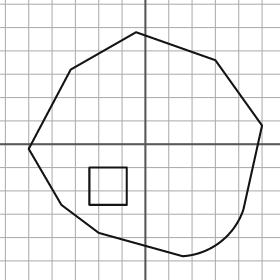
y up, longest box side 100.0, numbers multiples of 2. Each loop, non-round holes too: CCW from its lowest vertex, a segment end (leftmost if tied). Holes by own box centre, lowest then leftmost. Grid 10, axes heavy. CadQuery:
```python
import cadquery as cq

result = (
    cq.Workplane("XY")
    .moveTo(16.0, -48.0)
    .threePointArc((32.0, -42.0), (42.0, -28.0))
    .lineTo(50.0, 8.0)
    .lineTo(30.0, 36.0)
    .lineTo(-4.0, 48.0)
    .lineTo(-32.0, 32.0)
    .lineTo(-50.0, -2.0)
    .lineTo(-36.0, -26.0)
    .lineTo(-20.0, -38.0)
    .close()
    .moveTo(-24.0, -26.0)
    .lineTo(-8.0, -26.0)
    .lineTo(-8.0, -10.0)
    .lineTo(-24.0, -10.0)
    .close()
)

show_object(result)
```